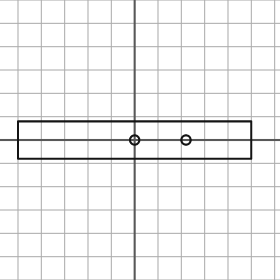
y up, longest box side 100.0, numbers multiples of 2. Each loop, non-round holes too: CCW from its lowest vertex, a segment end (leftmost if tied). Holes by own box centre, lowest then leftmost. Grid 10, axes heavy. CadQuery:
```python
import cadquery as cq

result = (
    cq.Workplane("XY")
    .moveTo(-50.0, -8.0)
    .lineTo(50.0, -8.0)
    .lineTo(50.0, 8.0)
    .lineTo(-50.0, 8.0)
    .close()
    .moveTo(0.0, 0.0)
    .circle(2.0)
    .moveTo(22.0, 0.0)
    .circle(2.0)
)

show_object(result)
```